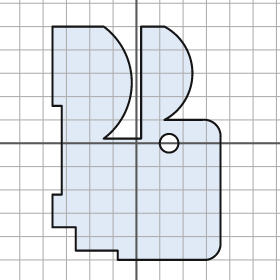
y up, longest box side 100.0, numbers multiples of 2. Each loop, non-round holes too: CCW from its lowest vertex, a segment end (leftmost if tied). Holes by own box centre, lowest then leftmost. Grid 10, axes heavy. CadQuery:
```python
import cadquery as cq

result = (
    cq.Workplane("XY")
    .moveTo(-8.0, -50.0)
    .lineTo(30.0, -50.0)
    .threePointArc((34.0, -48.0), (36.0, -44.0))
    .lineTo(36.0, 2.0)
    .threePointArc((34.0, 8.0), (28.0, 10.0))
    .lineTo(12.0, 10.0)
    .threePointArc((24.0, 30.0), (12.0, 50.0))
    .lineTo(2.0, 50.0)
    .lineTo(2.0, 2.0)
    .lineTo(-14.0, 2.0)
    .threePointArc((-2.0, 26.0), (-14.0, 50.0))
    .lineTo(-36.0, 50.0)
    .lineTo(-36.0, 16.0)
    .lineTo(-32.0, 16.0)
    .lineTo(-32.0, -22.0)
    .lineTo(-36.0, -22.0)
    .lineTo(-36.0, -36.0)
    .lineTo(-26.0, -36.0)
    .lineTo(-26.0, -46.0)
    .lineTo(-8.0, -46.0)
    .close()
    .moveTo(14.0, 0.0)
    .circle(4.0)
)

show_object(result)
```